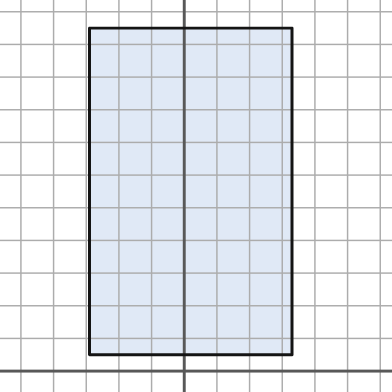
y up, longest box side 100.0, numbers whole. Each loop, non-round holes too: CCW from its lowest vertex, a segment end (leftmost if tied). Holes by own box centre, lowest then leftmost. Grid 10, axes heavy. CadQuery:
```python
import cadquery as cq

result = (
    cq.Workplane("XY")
    .moveTo(-29.0, 5.0)
    .lineTo(33.0, 5.0)
    .lineTo(33.0, 105.0)
    .lineTo(-29.0, 105.0)
    .close()
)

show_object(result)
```